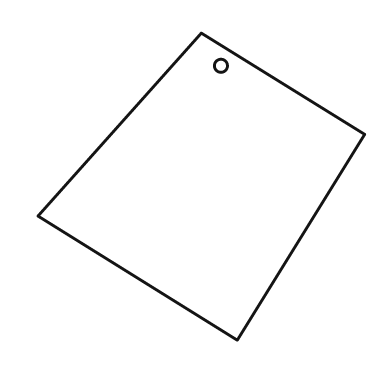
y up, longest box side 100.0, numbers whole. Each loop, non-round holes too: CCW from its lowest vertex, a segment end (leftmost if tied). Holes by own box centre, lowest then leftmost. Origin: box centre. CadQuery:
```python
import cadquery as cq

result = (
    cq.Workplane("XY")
    .moveTo(11.0, -47.0)
    .lineTo(50.0, 16.0)
    .lineTo(0.0, 47.0)
    .lineTo(-50.0, -9.0)
    .close()
    .moveTo(6.0, 37.0)
    .circle(2.0)
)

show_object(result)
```